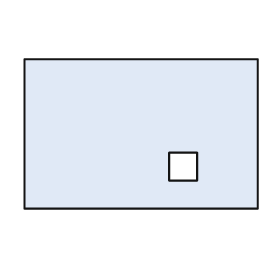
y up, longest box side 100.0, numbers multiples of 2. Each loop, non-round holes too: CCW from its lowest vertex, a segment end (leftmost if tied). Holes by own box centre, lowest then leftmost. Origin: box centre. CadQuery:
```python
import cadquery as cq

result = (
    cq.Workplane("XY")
    .moveTo(-50.0, -32.0)
    .lineTo(50.0, -32.0)
    .lineTo(50.0, 32.0)
    .lineTo(-50.0, 32.0)
    .close()
    .moveTo(12.0, -20.0)
    .lineTo(24.0, -20.0)
    .lineTo(24.0, -8.0)
    .lineTo(12.0, -8.0)
    .close()
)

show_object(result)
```